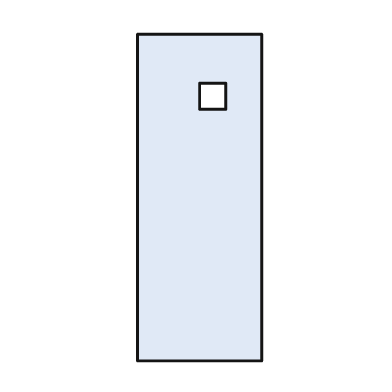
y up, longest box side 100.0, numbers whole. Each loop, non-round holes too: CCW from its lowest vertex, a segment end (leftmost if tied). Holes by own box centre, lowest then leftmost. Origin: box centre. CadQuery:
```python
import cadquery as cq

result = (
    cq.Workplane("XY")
    .moveTo(-19.0, -50.0)
    .lineTo(19.0, -50.0)
    .lineTo(19.0, 50.0)
    .lineTo(-19.0, 50.0)
    .close()
    .moveTo(0.0, 27.0)
    .lineTo(8.0, 27.0)
    .lineTo(8.0, 35.0)
    .lineTo(0.0, 35.0)
    .close()
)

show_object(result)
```